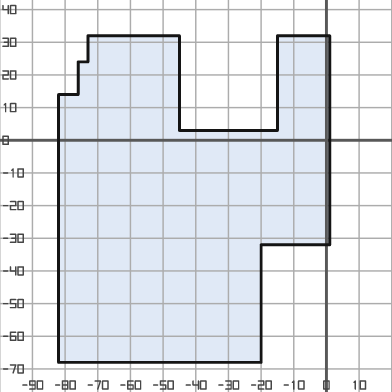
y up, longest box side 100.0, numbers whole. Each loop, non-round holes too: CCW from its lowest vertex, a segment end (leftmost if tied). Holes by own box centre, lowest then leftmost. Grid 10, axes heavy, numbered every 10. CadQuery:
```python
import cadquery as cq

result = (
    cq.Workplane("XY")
    .moveTo(-82.0, -68.0)
    .lineTo(-20.0, -68.0)
    .lineTo(-20.0, -32.0)
    .lineTo(1.0, -32.0)
    .lineTo(1.0, 32.0)
    .lineTo(-15.0, 32.0)
    .lineTo(-15.0, 3.0)
    .lineTo(-45.0, 3.0)
    .lineTo(-45.0, 32.0)
    .lineTo(-73.0, 32.0)
    .lineTo(-73.0, 24.0)
    .lineTo(-76.0, 24.0)
    .lineTo(-76.0, 14.0)
    .lineTo(-82.0, 14.0)
    .close()
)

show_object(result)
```